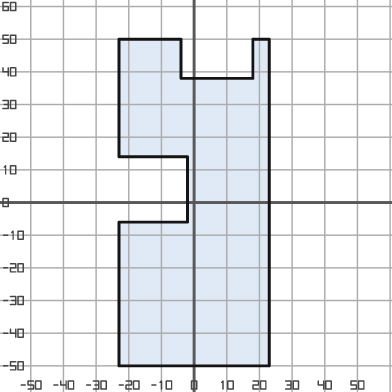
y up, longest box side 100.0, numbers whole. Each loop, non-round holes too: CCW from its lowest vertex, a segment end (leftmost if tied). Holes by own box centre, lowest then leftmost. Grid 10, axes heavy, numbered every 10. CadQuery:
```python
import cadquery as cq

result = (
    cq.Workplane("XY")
    .moveTo(-23.0, -50.0)
    .lineTo(23.0, -50.0)
    .lineTo(23.0, 50.0)
    .lineTo(18.0, 50.0)
    .lineTo(18.0, 38.0)
    .lineTo(-4.0, 38.0)
    .lineTo(-4.0, 50.0)
    .lineTo(-23.0, 50.0)
    .lineTo(-23.0, 14.0)
    .lineTo(-2.0, 14.0)
    .lineTo(-2.0, -6.0)
    .lineTo(-23.0, -6.0)
    .close()
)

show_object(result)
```